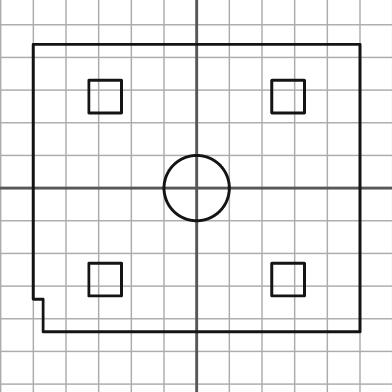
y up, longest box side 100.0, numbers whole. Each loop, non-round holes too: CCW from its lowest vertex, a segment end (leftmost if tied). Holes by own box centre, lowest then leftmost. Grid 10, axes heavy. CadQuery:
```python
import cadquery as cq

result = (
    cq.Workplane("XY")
    .moveTo(-47.0, -44.0)
    .lineTo(50.0, -44.0)
    .lineTo(50.0, 44.0)
    .lineTo(-50.0, 44.0)
    .lineTo(-50.0, -34.0)
    .lineTo(-47.0, -34.0)
    .close()
    .moveTo(-33.0, -33.0)
    .lineTo(-23.0, -33.0)
    .lineTo(-23.0, -23.0)
    .lineTo(-33.0, -23.0)
    .close()
    .moveTo(23.0, -33.0)
    .lineTo(33.0, -33.0)
    .lineTo(33.0, -23.0)
    .lineTo(23.0, -23.0)
    .close()
    .moveTo(0.0, 0.0)
    .circle(10.0)
    .moveTo(-33.0, 23.0)
    .lineTo(-23.0, 23.0)
    .lineTo(-23.0, 33.0)
    .lineTo(-33.0, 33.0)
    .close()
    .moveTo(23.0, 23.0)
    .lineTo(33.0, 23.0)
    .lineTo(33.0, 33.0)
    .lineTo(23.0, 33.0)
    .close()
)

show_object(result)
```